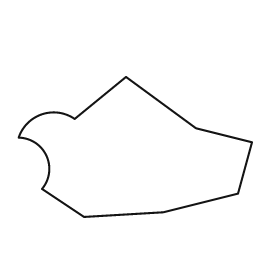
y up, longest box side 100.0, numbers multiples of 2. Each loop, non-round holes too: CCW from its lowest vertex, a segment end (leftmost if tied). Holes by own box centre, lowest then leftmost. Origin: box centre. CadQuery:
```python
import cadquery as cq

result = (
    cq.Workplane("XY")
    .moveTo(-22.0, -30.0)
    .lineTo(12.0, -28.0)
    .lineTo(44.0, -20.0)
    .lineTo(50.0, 2.0)
    .lineTo(26.0, 8.0)
    .lineTo(-4.0, 30.0)
    .lineTo(-26.0, 12.0)
    .threePointArc((-40.0, 14.0), (-50.0, 4.0))
    .threePointArc((-38.0, -4.0), (-40.0, -18.0))
    .close()
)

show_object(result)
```